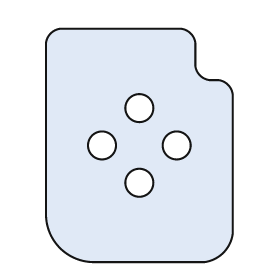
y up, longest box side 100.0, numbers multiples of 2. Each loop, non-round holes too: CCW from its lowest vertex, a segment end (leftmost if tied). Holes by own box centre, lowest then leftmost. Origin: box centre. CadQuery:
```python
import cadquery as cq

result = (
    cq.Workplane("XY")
    .moveTo(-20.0, -50.0)
    .lineTo(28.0, -50.0)
    .threePointArc((36.0, -46.0), (40.0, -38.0))
    .lineTo(40.0, 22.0)
    .threePointArc((38.0, 26.0), (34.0, 28.0))
    .lineTo(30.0, 28.0)
    .threePointArc((26.0, 30.0), (24.0, 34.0))
    .lineTo(24.0, 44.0)
    .threePointArc((22.0, 48.0), (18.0, 50.0))
    .lineTo(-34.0, 50.0)
    .threePointArc((-38.0, 48.0), (-40.0, 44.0))
    .lineTo(-40.0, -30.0)
    .threePointArc((-34.0, -44.0), (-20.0, -50.0))
    .close()
    .moveTo(0.0, -16.0)
    .circle(6.0)
    .moveTo(-16.0, 0.0)
    .circle(6.0)
    .moveTo(16.0, 0.0)
    .circle(6.0)
    .moveTo(0.0, 16.0)
    .circle(6.0)
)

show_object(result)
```